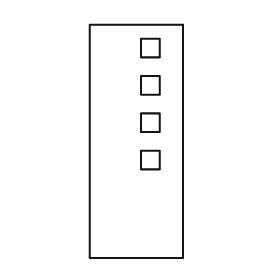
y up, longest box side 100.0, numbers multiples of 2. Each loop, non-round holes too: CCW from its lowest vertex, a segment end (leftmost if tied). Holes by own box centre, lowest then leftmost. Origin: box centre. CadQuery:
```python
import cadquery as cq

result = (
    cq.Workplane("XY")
    .moveTo(-20.0, -50.0)
    .lineTo(20.0, -50.0)
    .lineTo(20.0, 50.0)
    .lineTo(-20.0, 50.0)
    .close()
    .moveTo(2.0, -12.0)
    .lineTo(10.0, -12.0)
    .lineTo(10.0, -4.0)
    .lineTo(2.0, -4.0)
    .close()
    .moveTo(2.0, 4.0)
    .lineTo(10.0, 4.0)
    .lineTo(10.0, 12.0)
    .lineTo(2.0, 12.0)
    .close()
    .moveTo(2.0, 20.0)
    .lineTo(10.0, 20.0)
    .lineTo(10.0, 28.0)
    .lineTo(2.0, 28.0)
    .close()
    .moveTo(2.0, 36.0)
    .lineTo(10.0, 36.0)
    .lineTo(10.0, 44.0)
    .lineTo(2.0, 44.0)
    .close()
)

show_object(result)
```